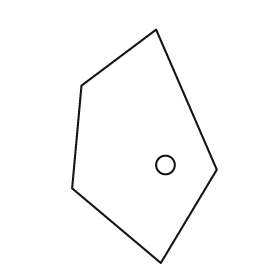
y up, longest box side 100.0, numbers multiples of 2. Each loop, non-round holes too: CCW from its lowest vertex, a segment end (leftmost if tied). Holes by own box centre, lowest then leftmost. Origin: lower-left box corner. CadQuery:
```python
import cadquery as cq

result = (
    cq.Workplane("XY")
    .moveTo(38.0, 0.0)
    .lineTo(62.0, 40.0)
    .lineTo(36.0, 100.0)
    .lineTo(4.0, 76.0)
    .lineTo(0.0, 32.0)
    .close()
    .moveTo(40.0, 42.0)
    .circle(4.0)
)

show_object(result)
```